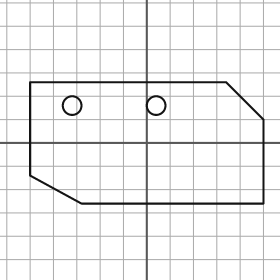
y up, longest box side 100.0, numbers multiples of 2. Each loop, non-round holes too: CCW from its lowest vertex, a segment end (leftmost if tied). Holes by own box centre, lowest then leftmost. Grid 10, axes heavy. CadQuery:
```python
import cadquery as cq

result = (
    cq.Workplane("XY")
    .moveTo(-28.0, -26.0)
    .lineTo(50.0, -26.0)
    .lineTo(50.0, 10.0)
    .lineTo(34.0, 26.0)
    .lineTo(-50.0, 26.0)
    .lineTo(-50.0, -14.0)
    .close()
    .moveTo(-32.0, 16.0)
    .circle(4.0)
    .moveTo(4.0, 16.0)
    .circle(4.0)
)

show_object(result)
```